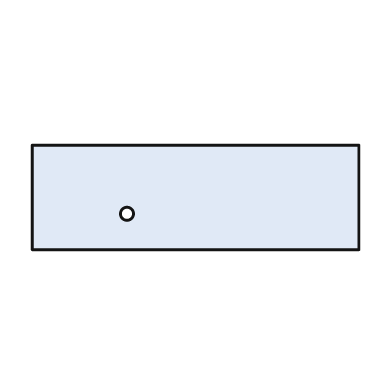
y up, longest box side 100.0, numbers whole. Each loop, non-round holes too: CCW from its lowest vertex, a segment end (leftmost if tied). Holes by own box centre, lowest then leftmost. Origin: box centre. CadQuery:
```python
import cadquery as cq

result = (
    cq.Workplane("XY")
    .moveTo(-50.0, -16.0)
    .lineTo(50.0, -16.0)
    .lineTo(50.0, 16.0)
    .lineTo(-50.0, 16.0)
    .close()
    .moveTo(-21.0, -5.0)
    .circle(2.0)
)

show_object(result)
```